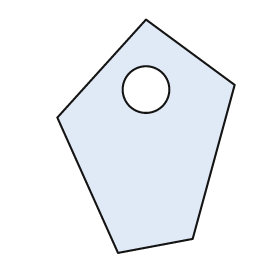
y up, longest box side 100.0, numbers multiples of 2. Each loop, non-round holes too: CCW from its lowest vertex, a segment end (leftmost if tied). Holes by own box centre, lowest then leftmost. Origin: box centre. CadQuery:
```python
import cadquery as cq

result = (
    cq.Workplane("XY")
    .moveTo(-12.0, -50.0)
    .lineTo(20.0, -44.0)
    .lineTo(38.0, 22.0)
    .lineTo(0.0, 50.0)
    .lineTo(-38.0, 8.0)
    .close()
    .moveTo(0.0, 20.0)
    .circle(10.0)
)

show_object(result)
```